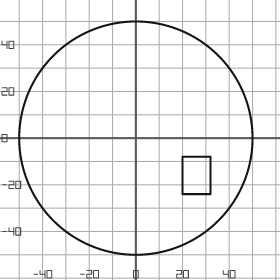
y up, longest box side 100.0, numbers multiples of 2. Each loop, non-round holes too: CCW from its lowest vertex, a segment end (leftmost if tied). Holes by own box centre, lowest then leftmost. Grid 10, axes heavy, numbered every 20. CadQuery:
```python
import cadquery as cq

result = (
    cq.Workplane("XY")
    .moveTo(0.0, 0.0)
    .circle(50.0)
    .moveTo(20.0, -24.0)
    .lineTo(32.0, -24.0)
    .lineTo(32.0, -8.0)
    .lineTo(20.0, -8.0)
    .close()
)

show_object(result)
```